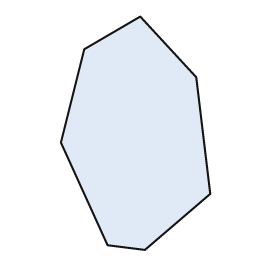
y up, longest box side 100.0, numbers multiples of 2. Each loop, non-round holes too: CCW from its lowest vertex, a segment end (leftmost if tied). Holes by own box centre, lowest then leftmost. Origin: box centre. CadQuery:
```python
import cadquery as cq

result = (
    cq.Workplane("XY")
    .moveTo(4.0, -50.0)
    .lineTo(32.0, -26.0)
    .lineTo(26.0, 24.0)
    .lineTo(2.0, 50.0)
    .lineTo(-22.0, 36.0)
    .lineTo(-32.0, -4.0)
    .lineTo(-12.0, -48.0)
    .close()
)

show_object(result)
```